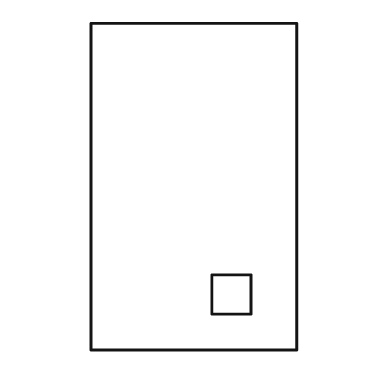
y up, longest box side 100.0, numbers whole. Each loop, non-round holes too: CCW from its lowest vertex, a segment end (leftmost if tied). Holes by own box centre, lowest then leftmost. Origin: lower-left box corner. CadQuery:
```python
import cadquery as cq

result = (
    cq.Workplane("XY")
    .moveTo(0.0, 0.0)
    .lineTo(63.0, 0.0)
    .lineTo(63.0, 100.0)
    .lineTo(0.0, 100.0)
    .close()
    .moveTo(37.0, 11.0)
    .lineTo(49.0, 11.0)
    .lineTo(49.0, 23.0)
    .lineTo(37.0, 23.0)
    .close()
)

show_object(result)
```